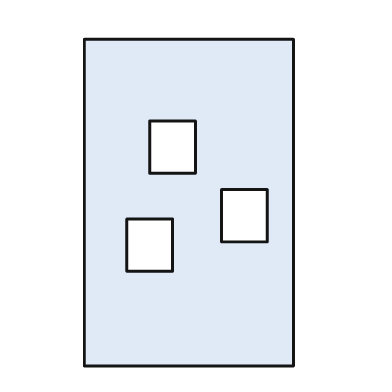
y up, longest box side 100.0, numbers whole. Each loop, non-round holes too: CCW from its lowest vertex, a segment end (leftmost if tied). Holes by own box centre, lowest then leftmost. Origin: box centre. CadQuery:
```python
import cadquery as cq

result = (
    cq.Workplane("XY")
    .moveTo(-32.0, -50.0)
    .lineTo(32.0, -50.0)
    .lineTo(32.0, 50.0)
    .lineTo(-32.0, 50.0)
    .close()
    .moveTo(-19.0, -21.0)
    .lineTo(-5.0, -21.0)
    .lineTo(-5.0, -5.0)
    .lineTo(-19.0, -5.0)
    .close()
    .moveTo(10.0, -12.0)
    .lineTo(24.0, -12.0)
    .lineTo(24.0, 4.0)
    .lineTo(10.0, 4.0)
    .close()
    .moveTo(-12.0, 9.0)
    .lineTo(2.0, 9.0)
    .lineTo(2.0, 25.0)
    .lineTo(-12.0, 25.0)
    .close()
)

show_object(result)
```